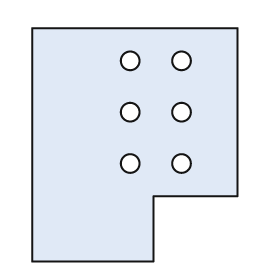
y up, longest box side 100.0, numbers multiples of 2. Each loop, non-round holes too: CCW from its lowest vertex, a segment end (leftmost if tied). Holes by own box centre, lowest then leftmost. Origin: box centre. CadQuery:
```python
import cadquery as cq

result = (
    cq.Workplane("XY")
    .moveTo(-44.0, -50.0)
    .lineTo(8.0, -50.0)
    .lineTo(8.0, -22.0)
    .lineTo(44.0, -22.0)
    .lineTo(44.0, 50.0)
    .lineTo(-44.0, 50.0)
    .close()
    .moveTo(-2.0, -8.0)
    .circle(4.0)
    .moveTo(20.0, -8.0)
    .circle(4.0)
    .moveTo(-2.0, 14.0)
    .circle(4.0)
    .moveTo(20.0, 14.0)
    .circle(4.0)
    .moveTo(-2.0, 36.0)
    .circle(4.0)
    .moveTo(20.0, 36.0)
    .circle(4.0)
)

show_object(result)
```